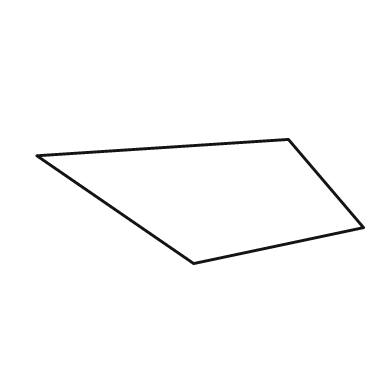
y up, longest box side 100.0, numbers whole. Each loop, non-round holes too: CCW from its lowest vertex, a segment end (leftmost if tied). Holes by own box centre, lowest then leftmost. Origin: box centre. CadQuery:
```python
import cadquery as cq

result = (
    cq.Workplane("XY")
    .moveTo(-2.0, -19.0)
    .lineTo(50.0, -8.0)
    .lineTo(27.0, 19.0)
    .lineTo(-50.0, 14.0)
    .close()
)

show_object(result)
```